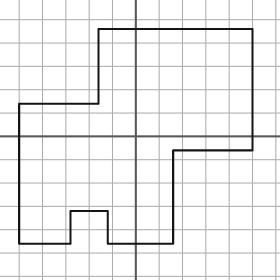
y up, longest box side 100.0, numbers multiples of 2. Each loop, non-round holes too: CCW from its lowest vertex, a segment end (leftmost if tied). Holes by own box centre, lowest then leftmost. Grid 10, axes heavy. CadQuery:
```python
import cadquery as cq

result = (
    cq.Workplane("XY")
    .moveTo(-50.0, -46.0)
    .lineTo(-28.0, -46.0)
    .lineTo(-28.0, -32.0)
    .lineTo(-12.0, -32.0)
    .lineTo(-12.0, -46.0)
    .lineTo(16.0, -46.0)
    .lineTo(16.0, -6.0)
    .lineTo(50.0, -6.0)
    .lineTo(50.0, 46.0)
    .lineTo(-16.0, 46.0)
    .lineTo(-16.0, 14.0)
    .lineTo(-50.0, 14.0)
    .close()
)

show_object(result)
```